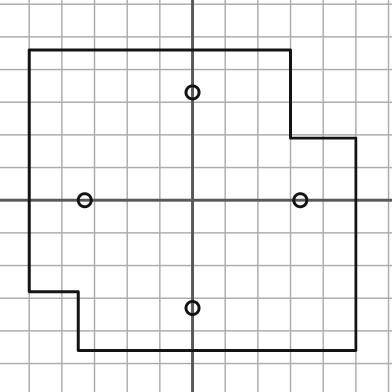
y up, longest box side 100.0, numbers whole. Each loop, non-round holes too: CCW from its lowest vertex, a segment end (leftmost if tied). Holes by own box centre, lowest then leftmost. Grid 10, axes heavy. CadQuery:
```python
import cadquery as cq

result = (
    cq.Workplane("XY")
    .moveTo(-35.0, -46.0)
    .lineTo(50.0, -46.0)
    .lineTo(50.0, 19.0)
    .lineTo(30.0, 19.0)
    .lineTo(30.0, 46.0)
    .lineTo(-50.0, 46.0)
    .lineTo(-50.0, -28.0)
    .lineTo(-35.0, -28.0)
    .close()
    .moveTo(0.0, -33.0)
    .circle(2.0)
    .moveTo(-33.0, 0.0)
    .circle(2.0)
    .moveTo(33.0, 0.0)
    .circle(2.0)
    .moveTo(0.0, 33.0)
    .circle(2.0)
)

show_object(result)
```